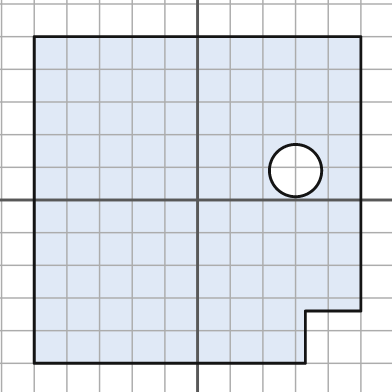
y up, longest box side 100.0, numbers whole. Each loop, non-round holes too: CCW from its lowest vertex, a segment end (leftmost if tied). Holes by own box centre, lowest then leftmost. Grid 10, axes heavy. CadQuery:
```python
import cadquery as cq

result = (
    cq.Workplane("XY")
    .moveTo(-50.0, -50.0)
    .lineTo(33.0, -50.0)
    .lineTo(33.0, -34.0)
    .lineTo(50.0, -34.0)
    .lineTo(50.0, 50.0)
    .lineTo(-50.0, 50.0)
    .close()
    .moveTo(30.0, 9.0)
    .circle(8.0)
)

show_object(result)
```